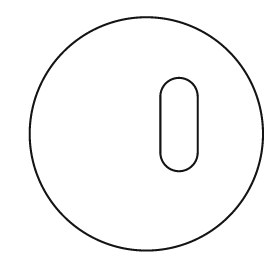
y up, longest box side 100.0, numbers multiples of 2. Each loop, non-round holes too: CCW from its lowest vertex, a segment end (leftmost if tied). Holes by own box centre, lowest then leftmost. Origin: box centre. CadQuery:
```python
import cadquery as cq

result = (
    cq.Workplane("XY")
    .moveTo(0.0, 0.0)
    .circle(50.0)
    .moveTo(6.0, -8.0)
    .threePointArc((14.0, -16.0), (22.0, -8.0))
    .lineTo(22.0, 16.0)
    .threePointArc((14.0, 24.0), (6.0, 16.0))
    .close()
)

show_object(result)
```